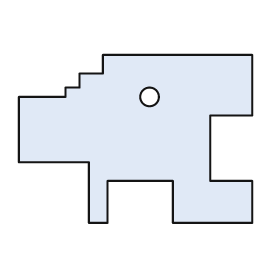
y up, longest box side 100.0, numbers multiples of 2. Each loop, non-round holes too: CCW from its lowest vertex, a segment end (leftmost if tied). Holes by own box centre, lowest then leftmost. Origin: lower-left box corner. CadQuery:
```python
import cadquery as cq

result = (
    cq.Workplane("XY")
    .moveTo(30.0, 0.0)
    .lineTo(38.0, 0.0)
    .lineTo(38.0, 18.0)
    .lineTo(66.0, 18.0)
    .lineTo(66.0, 0.0)
    .lineTo(100.0, 0.0)
    .lineTo(100.0, 18.0)
    .lineTo(82.0, 18.0)
    .lineTo(82.0, 46.0)
    .lineTo(100.0, 46.0)
    .lineTo(100.0, 72.0)
    .lineTo(36.0, 72.0)
    .lineTo(36.0, 64.0)
    .lineTo(26.0, 64.0)
    .lineTo(26.0, 58.0)
    .lineTo(20.0, 58.0)
    .lineTo(20.0, 54.0)
    .lineTo(0.0, 54.0)
    .lineTo(0.0, 26.0)
    .lineTo(30.0, 26.0)
    .close()
    .moveTo(56.0, 54.0)
    .circle(4.0)
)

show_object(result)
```